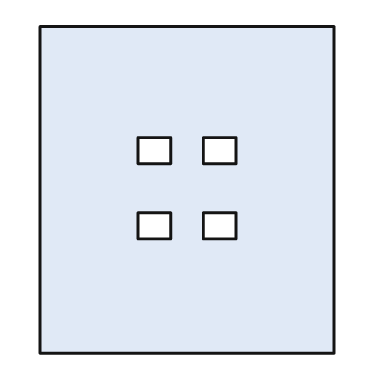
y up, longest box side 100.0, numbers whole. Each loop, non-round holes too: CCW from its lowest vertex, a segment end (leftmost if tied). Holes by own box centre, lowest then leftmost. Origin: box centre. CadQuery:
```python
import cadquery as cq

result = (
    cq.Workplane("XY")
    .moveTo(-45.0, -50.0)
    .lineTo(45.0, -50.0)
    .lineTo(45.0, 50.0)
    .lineTo(-45.0, 50.0)
    .close()
    .moveTo(-15.0, -15.0)
    .lineTo(-5.0, -15.0)
    .lineTo(-5.0, -7.0)
    .lineTo(-15.0, -7.0)
    .close()
    .moveTo(5.0, -15.0)
    .lineTo(15.0, -15.0)
    .lineTo(15.0, -7.0)
    .lineTo(5.0, -7.0)
    .close()
    .moveTo(-15.0, 8.0)
    .lineTo(-5.0, 8.0)
    .lineTo(-5.0, 16.0)
    .lineTo(-15.0, 16.0)
    .close()
    .moveTo(5.0, 8.0)
    .lineTo(15.0, 8.0)
    .lineTo(15.0, 16.0)
    .lineTo(5.0, 16.0)
    .close()
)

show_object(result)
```